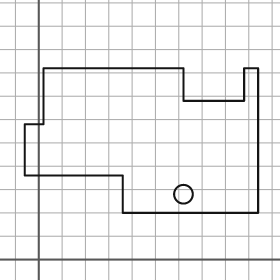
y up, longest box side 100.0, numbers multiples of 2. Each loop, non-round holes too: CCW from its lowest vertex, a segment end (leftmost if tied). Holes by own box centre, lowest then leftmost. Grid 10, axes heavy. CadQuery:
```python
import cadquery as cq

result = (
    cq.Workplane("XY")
    .moveTo(36.0, 20.0)
    .lineTo(94.0, 20.0)
    .lineTo(94.0, 82.0)
    .lineTo(88.0, 82.0)
    .lineTo(88.0, 68.0)
    .lineTo(62.0, 68.0)
    .lineTo(62.0, 82.0)
    .lineTo(2.0, 82.0)
    .lineTo(2.0, 58.0)
    .lineTo(-6.0, 58.0)
    .lineTo(-6.0, 36.0)
    .lineTo(36.0, 36.0)
    .close()
    .moveTo(62.0, 28.0)
    .circle(4.0)
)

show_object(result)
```